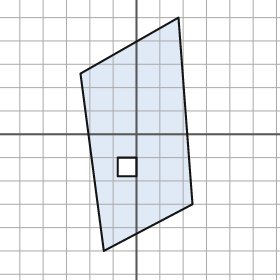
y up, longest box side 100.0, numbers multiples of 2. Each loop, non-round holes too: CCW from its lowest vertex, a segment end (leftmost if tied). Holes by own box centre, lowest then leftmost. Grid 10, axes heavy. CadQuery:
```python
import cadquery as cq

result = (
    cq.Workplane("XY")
    .moveTo(-14.0, -50.0)
    .lineTo(24.0, -30.0)
    .lineTo(18.0, 50.0)
    .lineTo(-24.0, 26.0)
    .close()
    .moveTo(-8.0, -18.0)
    .lineTo(0.0, -18.0)
    .lineTo(0.0, -10.0)
    .lineTo(-8.0, -10.0)
    .close()
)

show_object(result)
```